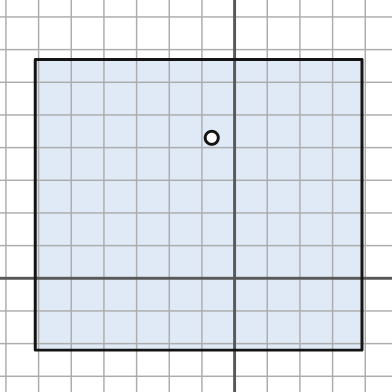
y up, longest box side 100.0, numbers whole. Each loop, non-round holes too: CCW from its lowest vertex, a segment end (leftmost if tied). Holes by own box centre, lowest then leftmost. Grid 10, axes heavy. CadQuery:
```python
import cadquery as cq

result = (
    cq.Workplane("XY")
    .moveTo(-61.0, -22.0)
    .lineTo(39.0, -22.0)
    .lineTo(39.0, 67.0)
    .lineTo(-61.0, 67.0)
    .close()
    .moveTo(-7.0, 43.0)
    .circle(2.0)
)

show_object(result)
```